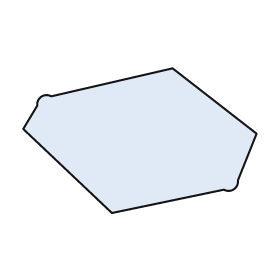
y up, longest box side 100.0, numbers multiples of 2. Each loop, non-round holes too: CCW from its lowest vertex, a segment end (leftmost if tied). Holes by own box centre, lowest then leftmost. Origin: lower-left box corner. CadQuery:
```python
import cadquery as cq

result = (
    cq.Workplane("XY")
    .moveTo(38.0, 0.0)
    .lineTo(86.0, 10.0)
    .threePointArc((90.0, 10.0), (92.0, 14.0))
    .lineTo(100.0, 34.0)
    .lineTo(64.0, 62.0)
    .lineTo(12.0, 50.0)
    .threePointArc((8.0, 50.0), (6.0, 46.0))
    .lineTo(0.0, 36.0)
    .close()
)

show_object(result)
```